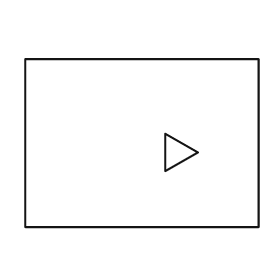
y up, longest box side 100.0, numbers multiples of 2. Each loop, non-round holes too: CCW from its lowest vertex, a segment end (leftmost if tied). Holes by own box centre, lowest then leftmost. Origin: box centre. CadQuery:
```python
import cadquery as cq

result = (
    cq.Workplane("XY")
    .moveTo(-50.0, -36.0)
    .lineTo(50.0, -36.0)
    .lineTo(50.0, 36.0)
    .lineTo(-50.0, 36.0)
    .close()
    .moveTo(10.0, -12.0)
    .lineTo(24.0, -4.0)
    .lineTo(10.0, 4.0)
    .close()
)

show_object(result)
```